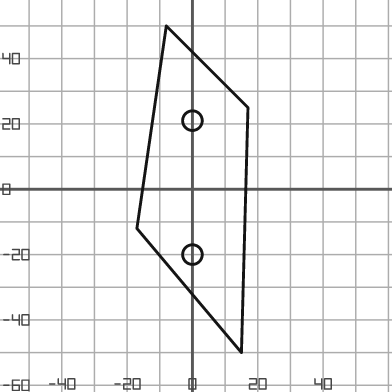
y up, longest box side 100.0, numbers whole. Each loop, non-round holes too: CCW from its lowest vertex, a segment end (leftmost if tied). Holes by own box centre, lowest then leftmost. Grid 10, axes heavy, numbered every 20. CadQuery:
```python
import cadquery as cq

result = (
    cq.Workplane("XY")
    .moveTo(15.0, -50.0)
    .lineTo(17.0, 25.0)
    .lineTo(-8.0, 50.0)
    .lineTo(-17.0, -12.0)
    .close()
    .moveTo(0.0, -20.0)
    .circle(3.0)
    .moveTo(0.0, 21.0)
    .circle(3.0)
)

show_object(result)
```